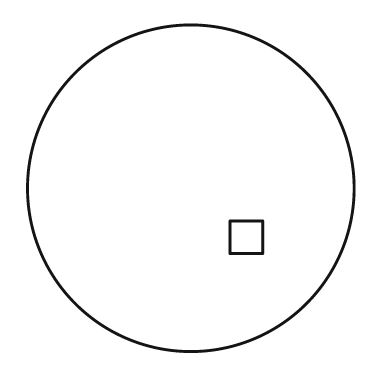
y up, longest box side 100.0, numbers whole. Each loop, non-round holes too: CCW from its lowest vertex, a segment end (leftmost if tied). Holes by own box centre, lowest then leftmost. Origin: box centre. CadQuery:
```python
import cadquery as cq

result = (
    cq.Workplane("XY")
    .moveTo(0.0, 0.0)
    .circle(50.0)
    .moveTo(12.0, -20.0)
    .lineTo(22.0, -20.0)
    .lineTo(22.0, -10.0)
    .lineTo(12.0, -10.0)
    .close()
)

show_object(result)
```